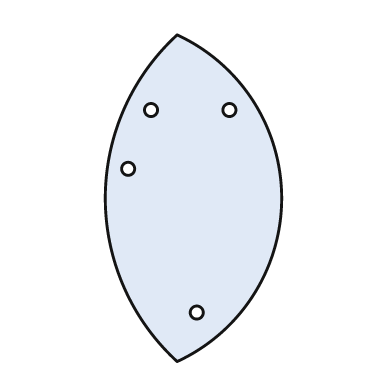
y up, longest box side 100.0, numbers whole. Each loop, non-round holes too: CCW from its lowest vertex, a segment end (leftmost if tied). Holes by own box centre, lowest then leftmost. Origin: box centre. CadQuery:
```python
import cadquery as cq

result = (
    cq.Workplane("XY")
    .moveTo(-5.0, -50.0)
    .threePointArc((27.0, 0.0), (-5.0, 50.0))
    .threePointArc((-27.0, 0.0), (-5.0, -50.0))
    .close()
    .moveTo(1.0, -35.0)
    .circle(2.0)
    .moveTo(-20.0, 9.0)
    .circle(2.0)
    .moveTo(-13.0, 27.0)
    .circle(2.0)
    .moveTo(11.0, 27.0)
    .circle(2.0)
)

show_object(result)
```